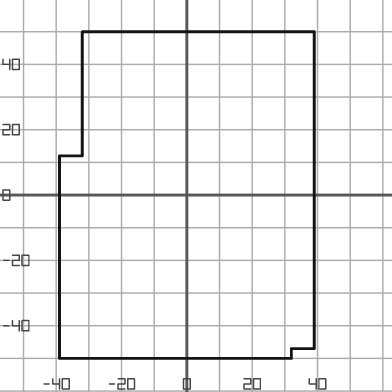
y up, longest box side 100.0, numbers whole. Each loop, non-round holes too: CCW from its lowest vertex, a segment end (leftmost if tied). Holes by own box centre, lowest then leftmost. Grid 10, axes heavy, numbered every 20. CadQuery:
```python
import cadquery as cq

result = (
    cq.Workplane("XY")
    .moveTo(-39.0, -50.0)
    .lineTo(32.0, -50.0)
    .lineTo(32.0, -47.0)
    .lineTo(39.0, -47.0)
    .lineTo(39.0, 50.0)
    .lineTo(-32.0, 50.0)
    .lineTo(-32.0, 12.0)
    .lineTo(-39.0, 12.0)
    .close()
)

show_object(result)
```